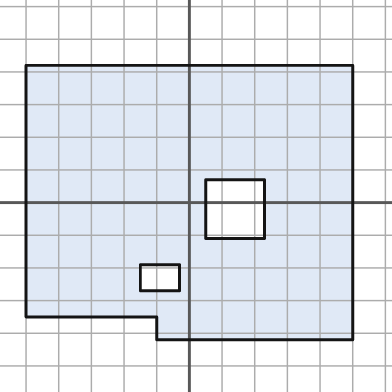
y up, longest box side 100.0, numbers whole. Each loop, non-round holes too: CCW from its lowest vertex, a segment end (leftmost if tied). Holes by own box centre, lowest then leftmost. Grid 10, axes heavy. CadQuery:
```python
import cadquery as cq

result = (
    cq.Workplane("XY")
    .moveTo(-10.0, -42.0)
    .lineTo(50.0, -42.0)
    .lineTo(50.0, 42.0)
    .lineTo(-50.0, 42.0)
    .lineTo(-50.0, -35.0)
    .lineTo(-10.0, -35.0)
    .close()
    .moveTo(-15.0, -27.0)
    .lineTo(-3.0, -27.0)
    .lineTo(-3.0, -19.0)
    .lineTo(-15.0, -19.0)
    .close()
    .moveTo(5.0, -11.0)
    .lineTo(23.0, -11.0)
    .lineTo(23.0, 7.0)
    .lineTo(5.0, 7.0)
    .close()
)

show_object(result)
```